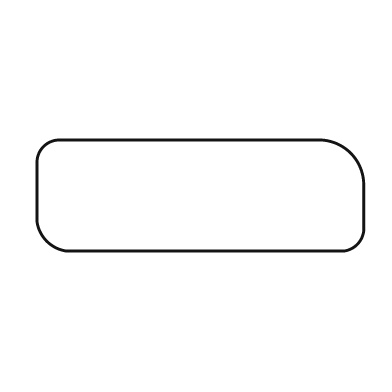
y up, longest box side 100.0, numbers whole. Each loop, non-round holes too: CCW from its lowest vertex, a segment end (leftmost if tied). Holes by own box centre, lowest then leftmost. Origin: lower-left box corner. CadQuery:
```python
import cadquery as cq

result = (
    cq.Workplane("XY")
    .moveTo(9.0, 0.0)
    .lineTo(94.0, 0.0)
    .threePointArc((98.0, 2.0), (100.0, 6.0))
    .lineTo(100.0, 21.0)
    .threePointArc((96.0, 30.0), (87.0, 34.0))
    .lineTo(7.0, 34.0)
    .threePointArc((2.0, 32.0), (0.0, 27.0))
    .lineTo(0.0, 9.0)
    .threePointArc((3.0, 3.0), (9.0, 0.0))
    .close()
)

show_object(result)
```